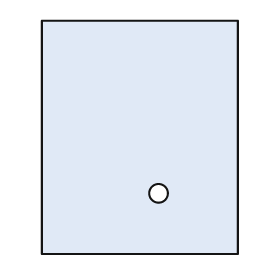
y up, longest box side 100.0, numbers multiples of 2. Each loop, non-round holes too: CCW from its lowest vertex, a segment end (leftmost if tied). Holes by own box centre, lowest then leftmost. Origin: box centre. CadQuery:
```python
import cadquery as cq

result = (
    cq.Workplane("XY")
    .moveTo(-42.0, -50.0)
    .lineTo(42.0, -50.0)
    .lineTo(42.0, 50.0)
    .lineTo(-42.0, 50.0)
    .close()
    .moveTo(8.0, -24.0)
    .circle(4.0)
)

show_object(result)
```